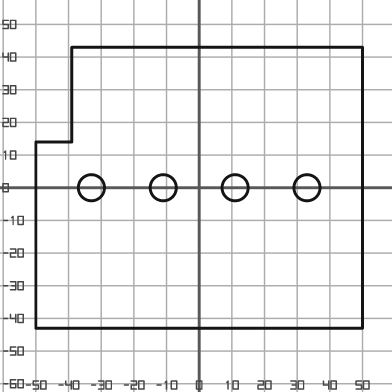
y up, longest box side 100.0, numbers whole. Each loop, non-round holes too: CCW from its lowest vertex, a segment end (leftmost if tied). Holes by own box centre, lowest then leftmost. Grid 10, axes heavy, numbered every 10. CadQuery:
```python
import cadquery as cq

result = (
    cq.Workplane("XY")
    .moveTo(-50.0, -43.0)
    .lineTo(50.0, -43.0)
    .lineTo(50.0, 43.0)
    .lineTo(-39.0, 43.0)
    .lineTo(-39.0, 14.0)
    .lineTo(-50.0, 14.0)
    .close()
    .moveTo(-33.0, 0.0)
    .circle(4.0)
    .moveTo(-11.0, 0.0)
    .circle(4.0)
    .moveTo(11.0, 0.0)
    .circle(4.0)
    .moveTo(33.0, 0.0)
    .circle(4.0)
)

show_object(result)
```